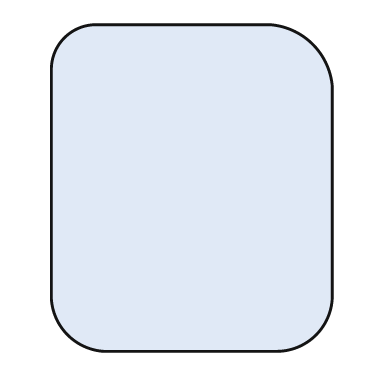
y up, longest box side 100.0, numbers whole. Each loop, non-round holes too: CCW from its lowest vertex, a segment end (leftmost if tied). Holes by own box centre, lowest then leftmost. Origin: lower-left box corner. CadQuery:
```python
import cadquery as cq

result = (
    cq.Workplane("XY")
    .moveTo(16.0, 0.0)
    .lineTo(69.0, 0.0)
    .threePointArc((81.0, 5.0), (86.0, 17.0))
    .lineTo(86.0, 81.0)
    .threePointArc((80.0, 94.0), (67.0, 100.0))
    .lineTo(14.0, 100.0)
    .threePointArc((4.0, 96.0), (0.0, 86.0))
    .lineTo(0.0, 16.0)
    .threePointArc((5.0, 5.0), (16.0, 0.0))
    .close()
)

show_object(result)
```